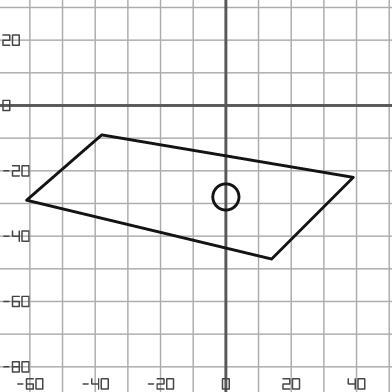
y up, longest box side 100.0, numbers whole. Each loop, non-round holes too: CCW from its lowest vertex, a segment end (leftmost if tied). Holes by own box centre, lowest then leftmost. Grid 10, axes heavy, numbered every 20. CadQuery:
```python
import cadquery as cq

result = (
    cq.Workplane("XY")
    .moveTo(14.0, -47.0)
    .lineTo(39.0, -22.0)
    .lineTo(-38.0, -9.0)
    .lineTo(-61.0, -29.0)
    .close()
    .moveTo(0.0, -28.0)
    .circle(4.0)
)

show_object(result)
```